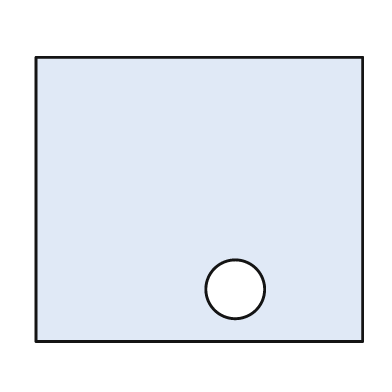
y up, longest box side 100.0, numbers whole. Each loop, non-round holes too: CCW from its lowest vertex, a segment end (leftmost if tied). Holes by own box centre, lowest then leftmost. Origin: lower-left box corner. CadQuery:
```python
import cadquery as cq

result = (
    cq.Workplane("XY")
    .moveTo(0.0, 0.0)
    .lineTo(100.0, 0.0)
    .lineTo(100.0, 87.0)
    .lineTo(0.0, 87.0)
    .close()
    .moveTo(61.0, 16.0)
    .circle(9.0)
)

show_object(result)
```